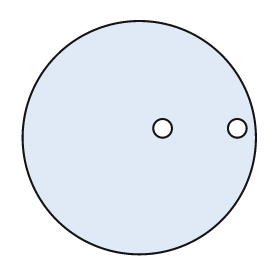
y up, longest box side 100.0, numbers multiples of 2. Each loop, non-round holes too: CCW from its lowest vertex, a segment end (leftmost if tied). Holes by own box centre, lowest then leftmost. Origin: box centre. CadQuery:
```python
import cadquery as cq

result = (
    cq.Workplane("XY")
    .moveTo(0.0, 0.0)
    .circle(50.0)
    .moveTo(10.0, 4.0)
    .circle(4.0)
    .moveTo(42.0, 4.0)
    .circle(4.0)
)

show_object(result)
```